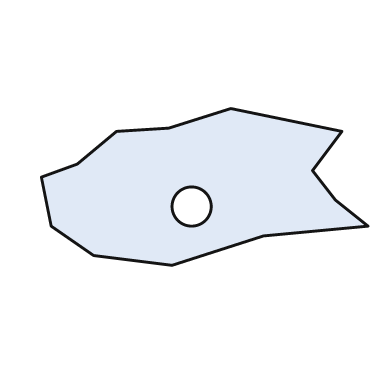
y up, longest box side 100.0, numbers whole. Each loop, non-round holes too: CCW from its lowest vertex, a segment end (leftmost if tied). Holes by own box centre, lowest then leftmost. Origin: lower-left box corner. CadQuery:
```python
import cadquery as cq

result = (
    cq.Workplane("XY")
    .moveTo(40.0, 0.0)
    .lineTo(68.0, 9.0)
    .lineTo(100.0, 12.0)
    .lineTo(90.0, 20.0)
    .lineTo(83.0, 29.0)
    .lineTo(92.0, 41.0)
    .lineTo(58.0, 48.0)
    .lineTo(39.0, 42.0)
    .lineTo(23.0, 41.0)
    .lineTo(11.0, 31.0)
    .lineTo(0.0, 27.0)
    .lineTo(3.0, 12.0)
    .lineTo(16.0, 3.0)
    .close()
    .moveTo(46.0, 18.0)
    .circle(6.0)
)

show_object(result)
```